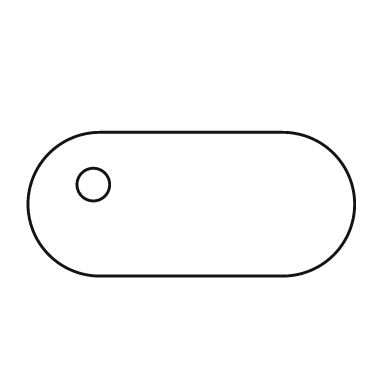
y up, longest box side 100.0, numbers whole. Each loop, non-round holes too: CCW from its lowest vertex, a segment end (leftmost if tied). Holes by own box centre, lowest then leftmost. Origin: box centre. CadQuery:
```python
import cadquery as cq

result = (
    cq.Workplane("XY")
    .moveTo(-28.0, -22.0)
    .lineTo(28.0, -22.0)
    .threePointArc((50.0, 0.0), (28.0, 22.0))
    .lineTo(-28.0, 22.0)
    .threePointArc((-50.0, 0.0), (-28.0, -22.0))
    .close()
    .moveTo(-30.0, 6.0)
    .circle(5.0)
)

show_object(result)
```